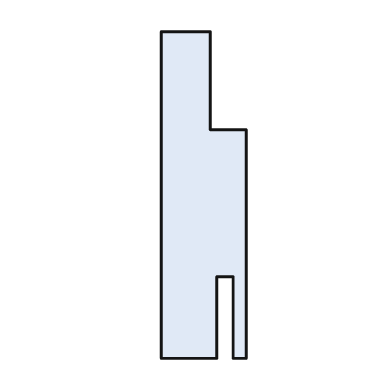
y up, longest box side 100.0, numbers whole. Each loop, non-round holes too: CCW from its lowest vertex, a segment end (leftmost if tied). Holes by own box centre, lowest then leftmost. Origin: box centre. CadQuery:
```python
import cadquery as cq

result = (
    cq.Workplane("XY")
    .moveTo(-13.0, -50.0)
    .lineTo(4.0, -50.0)
    .lineTo(4.0, -25.0)
    .lineTo(9.0, -25.0)
    .lineTo(9.0, -50.0)
    .lineTo(13.0, -50.0)
    .lineTo(13.0, 20.0)
    .lineTo(2.0, 20.0)
    .lineTo(2.0, 50.0)
    .lineTo(-13.0, 50.0)
    .close()
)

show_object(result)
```